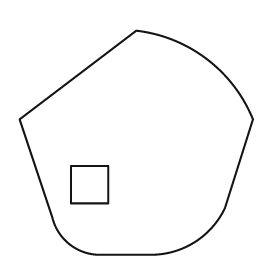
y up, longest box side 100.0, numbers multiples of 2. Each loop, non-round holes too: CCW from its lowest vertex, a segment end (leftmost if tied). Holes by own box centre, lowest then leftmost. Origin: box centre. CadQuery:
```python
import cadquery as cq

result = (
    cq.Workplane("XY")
    .moveTo(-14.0, -48.0)
    .lineTo(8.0, -48.0)
    .threePointArc((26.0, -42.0), (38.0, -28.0))
    .lineTo(50.0, 10.0)
    .threePointArc((30.0, 36.0), (0.0, 48.0))
    .lineTo(-50.0, 10.0)
    .lineTo(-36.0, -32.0)
    .threePointArc((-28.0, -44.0), (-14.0, -48.0))
    .close()
    .moveTo(-28.0, -26.0)
    .lineTo(-12.0, -26.0)
    .lineTo(-12.0, -10.0)
    .lineTo(-28.0, -10.0)
    .close()
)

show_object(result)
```